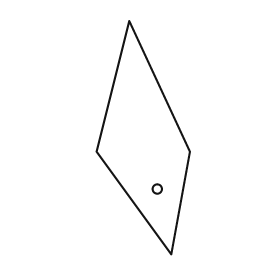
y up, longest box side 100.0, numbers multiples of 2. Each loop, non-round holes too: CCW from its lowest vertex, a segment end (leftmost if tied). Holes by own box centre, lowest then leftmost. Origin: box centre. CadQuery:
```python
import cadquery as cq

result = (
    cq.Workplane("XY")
    .moveTo(12.0, -50.0)
    .lineTo(20.0, -6.0)
    .lineTo(-6.0, 50.0)
    .lineTo(-20.0, -6.0)
    .close()
    .moveTo(6.0, -22.0)
    .circle(2.0)
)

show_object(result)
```